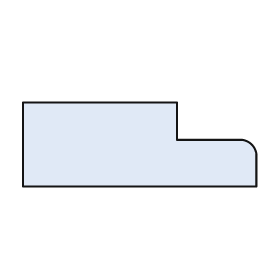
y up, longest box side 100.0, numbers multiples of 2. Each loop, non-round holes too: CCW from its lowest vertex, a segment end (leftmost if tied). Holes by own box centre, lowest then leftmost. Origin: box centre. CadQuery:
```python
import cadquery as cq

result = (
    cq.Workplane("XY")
    .moveTo(-50.0, -18.0)
    .lineTo(50.0, -18.0)
    .lineTo(50.0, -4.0)
    .threePointArc((48.0, 0.0), (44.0, 2.0))
    .lineTo(16.0, 2.0)
    .lineTo(16.0, 18.0)
    .lineTo(-50.0, 18.0)
    .close()
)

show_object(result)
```